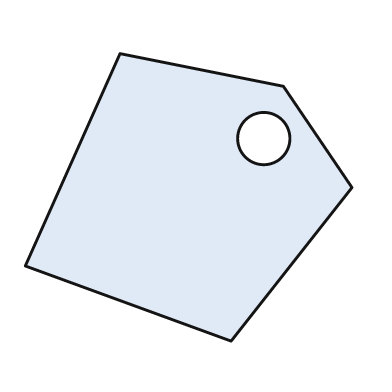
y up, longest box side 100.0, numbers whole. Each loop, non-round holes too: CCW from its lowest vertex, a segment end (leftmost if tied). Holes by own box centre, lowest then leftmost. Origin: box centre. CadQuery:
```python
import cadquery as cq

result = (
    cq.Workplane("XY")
    .moveTo(13.0, -44.0)
    .lineTo(50.0, 3.0)
    .lineTo(29.0, 34.0)
    .lineTo(-21.0, 44.0)
    .lineTo(-50.0, -21.0)
    .close()
    .moveTo(23.0, 18.0)
    .circle(8.0)
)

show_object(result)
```